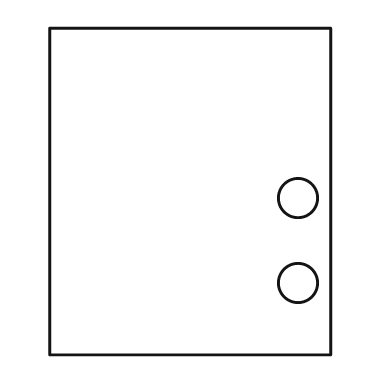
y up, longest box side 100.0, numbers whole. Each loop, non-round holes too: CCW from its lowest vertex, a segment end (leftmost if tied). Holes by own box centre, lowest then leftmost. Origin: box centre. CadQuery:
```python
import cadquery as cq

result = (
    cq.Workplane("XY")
    .moveTo(-43.0, -50.0)
    .lineTo(43.0, -50.0)
    .lineTo(43.0, 50.0)
    .lineTo(-43.0, 50.0)
    .close()
    .moveTo(33.0, -28.0)
    .circle(6.0)
    .moveTo(33.0, -2.0)
    .circle(6.0)
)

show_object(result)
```